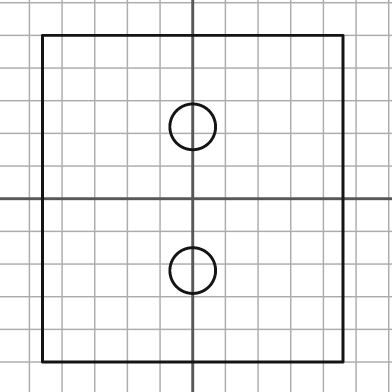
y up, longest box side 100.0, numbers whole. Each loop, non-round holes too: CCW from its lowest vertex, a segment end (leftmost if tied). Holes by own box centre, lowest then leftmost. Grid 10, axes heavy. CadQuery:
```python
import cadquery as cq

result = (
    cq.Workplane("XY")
    .moveTo(-46.0, -50.0)
    .lineTo(46.0, -50.0)
    .lineTo(46.0, 50.0)
    .lineTo(-46.0, 50.0)
    .close()
    .moveTo(0.0, -22.0)
    .circle(7.0)
    .moveTo(0.0, 22.0)
    .circle(7.0)
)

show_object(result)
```